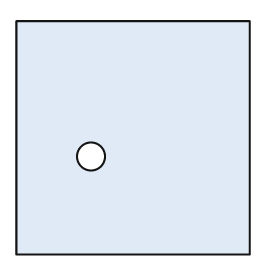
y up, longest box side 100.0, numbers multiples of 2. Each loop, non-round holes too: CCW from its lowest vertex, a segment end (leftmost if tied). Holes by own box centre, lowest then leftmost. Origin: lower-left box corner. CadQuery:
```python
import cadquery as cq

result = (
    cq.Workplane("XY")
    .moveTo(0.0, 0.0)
    .lineTo(100.0, 0.0)
    .lineTo(100.0, 100.0)
    .lineTo(0.0, 100.0)
    .close()
    .moveTo(32.0, 42.0)
    .circle(6.0)
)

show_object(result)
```